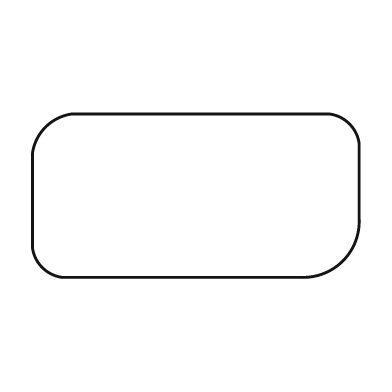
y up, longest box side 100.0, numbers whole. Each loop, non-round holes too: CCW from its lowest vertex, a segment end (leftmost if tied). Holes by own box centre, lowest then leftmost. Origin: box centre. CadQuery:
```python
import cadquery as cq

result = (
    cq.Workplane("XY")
    .moveTo(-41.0, -25.0)
    .lineTo(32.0, -25.0)
    .threePointArc((45.0, -20.0), (50.0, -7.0))
    .lineTo(50.0, 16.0)
    .threePointArc((47.0, 22.0), (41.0, 25.0))
    .lineTo(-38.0, 25.0)
    .threePointArc((-46.0, 21.0), (-50.0, 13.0))
    .lineTo(-50.0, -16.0)
    .threePointArc((-47.0, -22.0), (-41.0, -25.0))
    .close()
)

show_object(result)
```